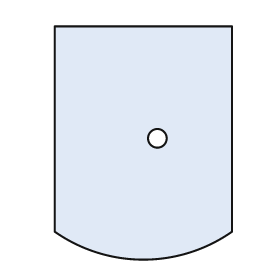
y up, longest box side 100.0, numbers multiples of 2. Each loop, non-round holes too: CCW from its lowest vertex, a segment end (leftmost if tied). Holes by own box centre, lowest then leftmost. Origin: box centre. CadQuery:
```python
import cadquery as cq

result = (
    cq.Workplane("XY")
    .moveTo(-38.0, -38.0)
    .threePointArc((0.0, -50.0), (38.0, -38.0))
    .lineTo(38.0, 50.0)
    .lineTo(-38.0, 50.0)
    .close()
    .moveTo(6.0, 2.0)
    .circle(4.0)
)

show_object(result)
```